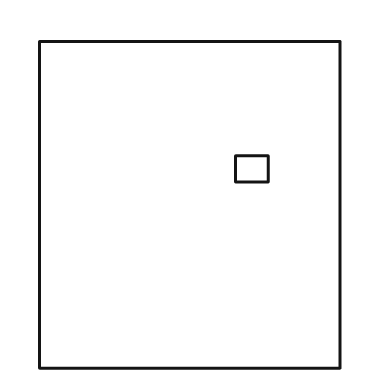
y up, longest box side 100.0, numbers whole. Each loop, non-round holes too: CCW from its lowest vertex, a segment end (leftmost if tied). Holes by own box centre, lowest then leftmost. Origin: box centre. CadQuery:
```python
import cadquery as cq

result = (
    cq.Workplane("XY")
    .moveTo(-46.0, -50.0)
    .lineTo(46.0, -50.0)
    .lineTo(46.0, 50.0)
    .lineTo(-46.0, 50.0)
    .close()
    .moveTo(14.0, 7.0)
    .lineTo(24.0, 7.0)
    .lineTo(24.0, 15.0)
    .lineTo(14.0, 15.0)
    .close()
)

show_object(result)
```